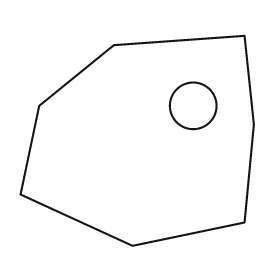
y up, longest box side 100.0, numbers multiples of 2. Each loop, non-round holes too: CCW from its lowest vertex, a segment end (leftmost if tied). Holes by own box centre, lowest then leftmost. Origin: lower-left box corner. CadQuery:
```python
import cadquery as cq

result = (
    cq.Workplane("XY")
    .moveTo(48.0, 0.0)
    .lineTo(96.0, 10.0)
    .lineTo(100.0, 52.0)
    .lineTo(96.0, 90.0)
    .lineTo(40.0, 86.0)
    .lineTo(8.0, 60.0)
    .lineTo(0.0, 22.0)
    .close()
    .moveTo(74.0, 60.0)
    .circle(10.0)
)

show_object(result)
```